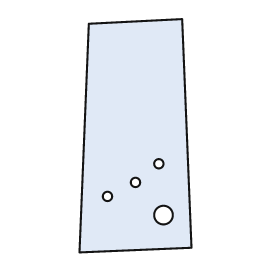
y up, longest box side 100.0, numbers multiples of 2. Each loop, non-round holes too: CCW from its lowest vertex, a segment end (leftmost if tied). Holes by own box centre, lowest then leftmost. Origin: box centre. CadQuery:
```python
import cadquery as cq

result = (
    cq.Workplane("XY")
    .moveTo(-24.0, -50.0)
    .lineTo(24.0, -48.0)
    .lineTo(20.0, 50.0)
    .lineTo(-20.0, 48.0)
    .close()
    .moveTo(12.0, -34.0)
    .circle(4.0)
    .moveTo(-12.0, -26.0)
    .circle(2.0)
    .moveTo(0.0, -20.0)
    .circle(2.0)
    .moveTo(10.0, -12.0)
    .circle(2.0)
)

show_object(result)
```